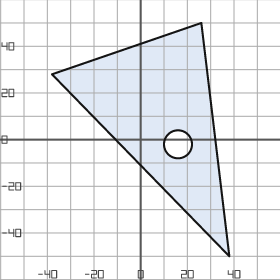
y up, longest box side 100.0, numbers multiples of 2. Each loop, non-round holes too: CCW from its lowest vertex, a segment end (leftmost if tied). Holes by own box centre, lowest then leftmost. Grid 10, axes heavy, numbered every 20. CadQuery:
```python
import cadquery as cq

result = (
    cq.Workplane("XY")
    .moveTo(38.0, -50.0)
    .lineTo(26.0, 50.0)
    .lineTo(-38.0, 28.0)
    .close()
    .moveTo(16.0, -2.0)
    .circle(6.0)
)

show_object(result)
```